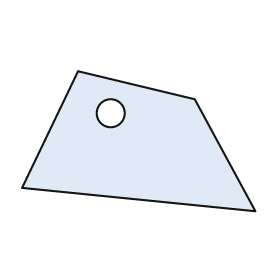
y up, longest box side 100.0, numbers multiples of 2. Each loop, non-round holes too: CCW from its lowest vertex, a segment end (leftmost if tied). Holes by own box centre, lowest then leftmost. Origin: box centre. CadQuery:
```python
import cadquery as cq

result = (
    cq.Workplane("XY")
    .moveTo(50.0, -30.0)
    .lineTo(24.0, 18.0)
    .lineTo(-26.0, 30.0)
    .lineTo(-50.0, -20.0)
    .close()
    .moveTo(-12.0, 12.0)
    .circle(6.0)
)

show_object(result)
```